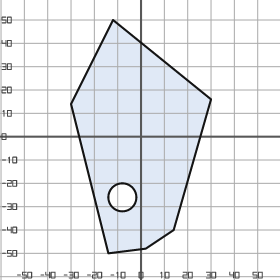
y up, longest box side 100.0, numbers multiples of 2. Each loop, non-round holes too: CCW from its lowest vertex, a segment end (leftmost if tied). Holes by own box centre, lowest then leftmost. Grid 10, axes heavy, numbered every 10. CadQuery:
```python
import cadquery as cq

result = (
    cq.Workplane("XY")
    .moveTo(-14.0, -50.0)
    .lineTo(2.0, -48.0)
    .lineTo(14.0, -40.0)
    .lineTo(30.0, 16.0)
    .lineTo(-12.0, 50.0)
    .lineTo(-30.0, 14.0)
    .close()
    .moveTo(-8.0, -26.0)
    .circle(6.0)
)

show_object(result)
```